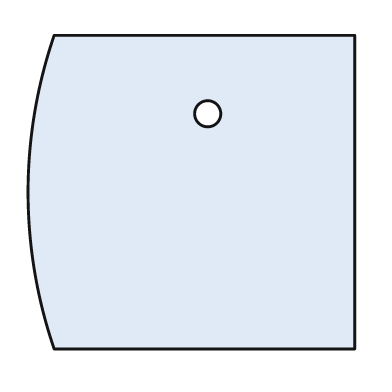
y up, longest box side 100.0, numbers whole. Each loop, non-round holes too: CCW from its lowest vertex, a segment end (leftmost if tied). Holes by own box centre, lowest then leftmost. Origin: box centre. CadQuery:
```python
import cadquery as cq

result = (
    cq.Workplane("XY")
    .moveTo(-42.0, -48.0)
    .lineTo(50.0, -48.0)
    .lineTo(50.0, 48.0)
    .lineTo(-42.0, 48.0)
    .threePointArc((-50.0, 0.0), (-42.0, -48.0))
    .close()
    .moveTo(5.0, 24.0)
    .circle(4.0)
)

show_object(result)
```